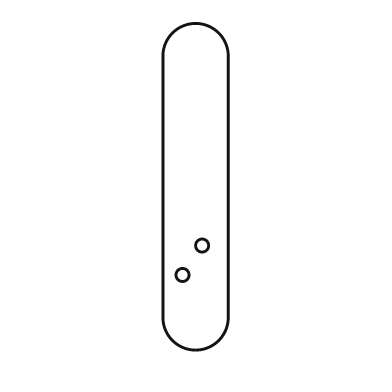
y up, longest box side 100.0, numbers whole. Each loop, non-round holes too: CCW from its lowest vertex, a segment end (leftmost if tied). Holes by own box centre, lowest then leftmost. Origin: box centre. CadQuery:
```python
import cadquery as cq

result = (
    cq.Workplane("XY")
    .moveTo(-10.0, -40.0)
    .threePointArc((0.0, -50.0), (10.0, -40.0))
    .lineTo(10.0, 40.0)
    .threePointArc((0.0, 50.0), (-10.0, 40.0))
    .close()
    .moveTo(-4.0, -27.0)
    .circle(2.0)
    .moveTo(2.0, -18.0)
    .circle(2.0)
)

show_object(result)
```